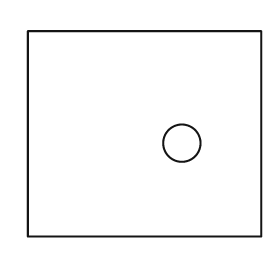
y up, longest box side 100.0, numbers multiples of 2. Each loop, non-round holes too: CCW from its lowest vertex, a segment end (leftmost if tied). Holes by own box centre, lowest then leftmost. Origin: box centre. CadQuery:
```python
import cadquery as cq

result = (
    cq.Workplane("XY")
    .moveTo(-50.0, -44.0)
    .lineTo(50.0, -44.0)
    .lineTo(50.0, 44.0)
    .lineTo(-50.0, 44.0)
    .close()
    .moveTo(16.0, -4.0)
    .circle(8.0)
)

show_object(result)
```